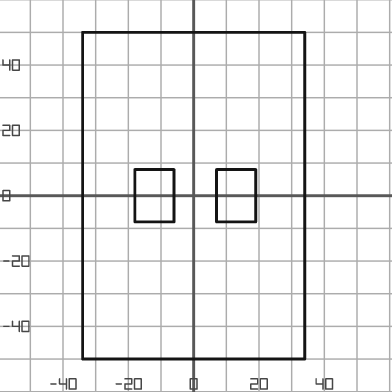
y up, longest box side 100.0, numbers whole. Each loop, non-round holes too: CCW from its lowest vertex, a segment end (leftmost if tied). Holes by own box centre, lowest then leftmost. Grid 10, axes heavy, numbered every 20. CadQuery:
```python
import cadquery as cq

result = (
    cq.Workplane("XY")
    .moveTo(-34.0, -50.0)
    .lineTo(34.0, -50.0)
    .lineTo(34.0, 50.0)
    .lineTo(-34.0, 50.0)
    .close()
    .moveTo(-18.0, -8.0)
    .lineTo(-6.0, -8.0)
    .lineTo(-6.0, 8.0)
    .lineTo(-18.0, 8.0)
    .close()
    .moveTo(7.0, -8.0)
    .lineTo(19.0, -8.0)
    .lineTo(19.0, 8.0)
    .lineTo(7.0, 8.0)
    .close()
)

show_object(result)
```